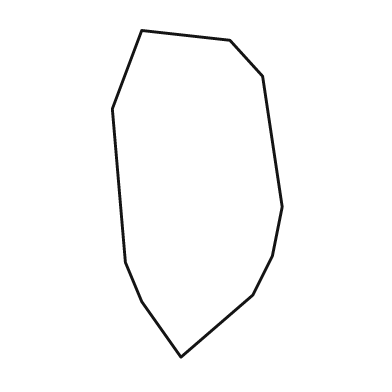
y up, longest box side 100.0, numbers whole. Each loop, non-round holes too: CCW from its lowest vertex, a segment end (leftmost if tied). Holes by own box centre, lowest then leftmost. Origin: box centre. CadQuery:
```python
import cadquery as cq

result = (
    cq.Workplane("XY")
    .moveTo(-5.0, -50.0)
    .lineTo(17.0, -31.0)
    .lineTo(23.0, -19.0)
    .lineTo(26.0, -4.0)
    .lineTo(20.0, 36.0)
    .lineTo(10.0, 47.0)
    .lineTo(-17.0, 50.0)
    .lineTo(-26.0, 26.0)
    .lineTo(-22.0, -21.0)
    .lineTo(-17.0, -33.0)
    .close()
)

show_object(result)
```